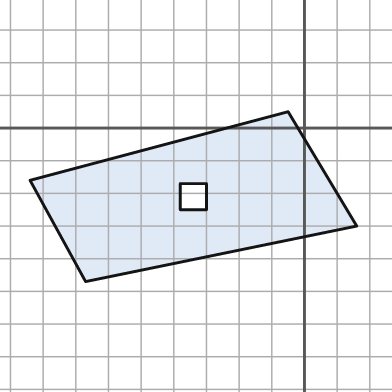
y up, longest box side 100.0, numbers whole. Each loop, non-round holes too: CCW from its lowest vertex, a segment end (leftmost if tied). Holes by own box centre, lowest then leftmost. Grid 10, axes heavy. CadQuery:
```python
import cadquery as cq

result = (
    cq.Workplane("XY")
    .moveTo(-67.0, -47.0)
    .lineTo(16.0, -30.0)
    .lineTo(-5.0, 5.0)
    .lineTo(-84.0, -16.0)
    .close()
    .moveTo(-38.0, -25.0)
    .lineTo(-30.0, -25.0)
    .lineTo(-30.0, -17.0)
    .lineTo(-38.0, -17.0)
    .close()
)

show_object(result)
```